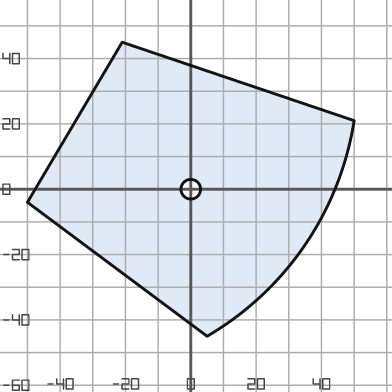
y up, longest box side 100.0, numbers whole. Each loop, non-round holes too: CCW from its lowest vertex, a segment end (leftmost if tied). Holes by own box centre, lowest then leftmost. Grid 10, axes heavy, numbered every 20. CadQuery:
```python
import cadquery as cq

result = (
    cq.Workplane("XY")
    .moveTo(5.0, -45.0)
    .threePointArc((35.0, -17.0), (50.0, 21.0))
    .lineTo(-21.0, 45.0)
    .lineTo(-50.0, -4.0)
    .close()
    .moveTo(0.0, 0.0)
    .circle(3.0)
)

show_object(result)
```